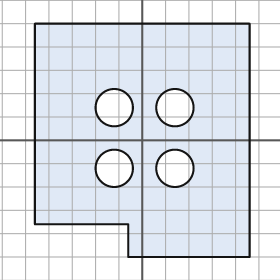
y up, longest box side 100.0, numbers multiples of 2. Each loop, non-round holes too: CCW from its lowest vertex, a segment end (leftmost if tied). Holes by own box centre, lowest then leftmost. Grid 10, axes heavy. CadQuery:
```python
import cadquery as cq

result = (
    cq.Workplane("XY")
    .moveTo(-6.0, -50.0)
    .lineTo(46.0, -50.0)
    .lineTo(46.0, 50.0)
    .lineTo(-46.0, 50.0)
    .lineTo(-46.0, -36.0)
    .lineTo(-6.0, -36.0)
    .close()
    .moveTo(-12.0, -12.0)
    .circle(8.0)
    .moveTo(14.0, -12.0)
    .circle(8.0)
    .moveTo(-12.0, 14.0)
    .circle(8.0)
    .moveTo(14.0, 14.0)
    .circle(8.0)
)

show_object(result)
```